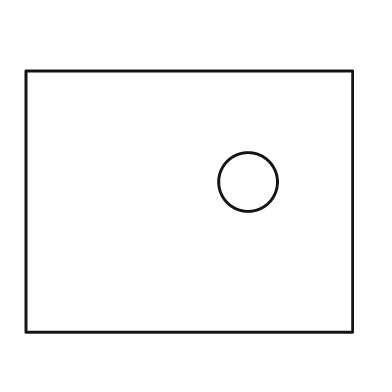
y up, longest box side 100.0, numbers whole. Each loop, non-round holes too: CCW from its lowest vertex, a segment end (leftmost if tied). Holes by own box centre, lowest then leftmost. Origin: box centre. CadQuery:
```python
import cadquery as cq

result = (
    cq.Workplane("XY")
    .moveTo(-50.0, -40.0)
    .lineTo(50.0, -40.0)
    .lineTo(50.0, 40.0)
    .lineTo(-50.0, 40.0)
    .close()
    .moveTo(18.0, 6.0)
    .circle(9.0)
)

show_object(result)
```